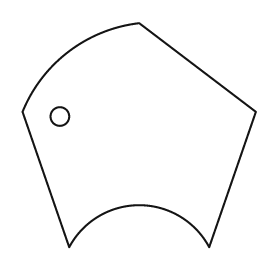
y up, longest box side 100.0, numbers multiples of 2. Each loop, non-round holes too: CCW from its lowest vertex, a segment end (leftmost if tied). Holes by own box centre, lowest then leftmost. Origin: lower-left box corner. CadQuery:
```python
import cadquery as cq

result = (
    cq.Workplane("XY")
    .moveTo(20.0, 0.0)
    .threePointArc((50.0, 18.0), (80.0, 0.0))
    .lineTo(100.0, 58.0)
    .lineTo(50.0, 96.0)
    .threePointArc((20.0, 84.0), (0.0, 58.0))
    .close()
    .moveTo(16.0, 56.0)
    .circle(4.0)
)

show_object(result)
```